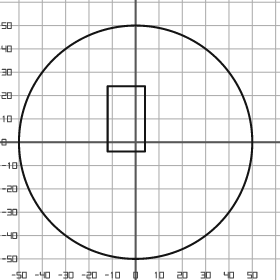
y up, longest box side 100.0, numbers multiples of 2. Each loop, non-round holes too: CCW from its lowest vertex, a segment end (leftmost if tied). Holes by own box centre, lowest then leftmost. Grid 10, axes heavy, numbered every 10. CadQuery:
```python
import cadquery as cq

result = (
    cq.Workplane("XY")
    .moveTo(0.0, 0.0)
    .circle(50.0)
    .moveTo(-12.0, -4.0)
    .lineTo(4.0, -4.0)
    .lineTo(4.0, 24.0)
    .lineTo(-12.0, 24.0)
    .close()
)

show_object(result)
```